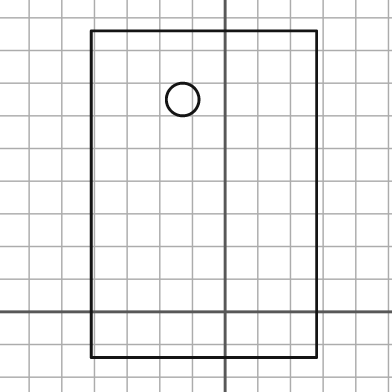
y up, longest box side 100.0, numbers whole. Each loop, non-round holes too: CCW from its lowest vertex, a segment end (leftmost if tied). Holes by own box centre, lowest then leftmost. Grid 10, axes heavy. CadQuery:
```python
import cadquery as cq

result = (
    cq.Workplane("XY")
    .moveTo(-41.0, -14.0)
    .lineTo(28.0, -14.0)
    .lineTo(28.0, 86.0)
    .lineTo(-41.0, 86.0)
    .close()
    .moveTo(-13.0, 65.0)
    .circle(5.0)
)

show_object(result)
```